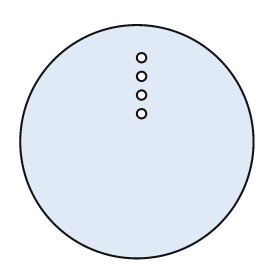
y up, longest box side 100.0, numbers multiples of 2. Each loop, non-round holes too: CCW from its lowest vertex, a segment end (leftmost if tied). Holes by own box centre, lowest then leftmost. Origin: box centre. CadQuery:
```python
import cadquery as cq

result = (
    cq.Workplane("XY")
    .moveTo(0.0, 0.0)
    .circle(50.0)
    .moveTo(2.0, 12.0)
    .circle(2.0)
    .moveTo(2.0, 20.0)
    .circle(2.0)
    .moveTo(2.0, 28.0)
    .circle(2.0)
    .moveTo(2.0, 36.0)
    .circle(2.0)
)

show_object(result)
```